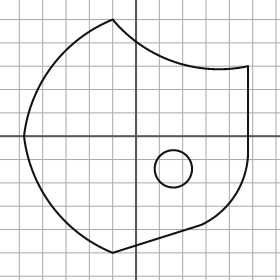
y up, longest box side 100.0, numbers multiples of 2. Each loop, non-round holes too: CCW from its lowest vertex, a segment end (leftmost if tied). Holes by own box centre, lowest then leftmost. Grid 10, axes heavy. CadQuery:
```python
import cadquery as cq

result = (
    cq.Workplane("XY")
    .moveTo(-10.0, -50.0)
    .lineTo(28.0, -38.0)
    .threePointArc((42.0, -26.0), (48.0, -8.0))
    .lineTo(48.0, 30.0)
    .threePointArc((16.0, 32.0), (-10.0, 50.0))
    .threePointArc((-36.0, 30.0), (-48.0, 0.0))
    .threePointArc((-36.0, -30.0), (-10.0, -50.0))
    .close()
    .moveTo(16.0, -14.0)
    .circle(8.0)
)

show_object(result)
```